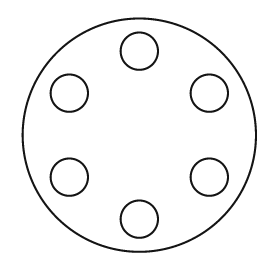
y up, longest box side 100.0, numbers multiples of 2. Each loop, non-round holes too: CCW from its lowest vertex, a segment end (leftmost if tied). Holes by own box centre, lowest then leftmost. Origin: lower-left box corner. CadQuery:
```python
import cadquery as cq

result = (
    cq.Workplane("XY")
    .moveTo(50.0, 50.0)
    .circle(50.0)
    .moveTo(50.0, 14.0)
    .circle(8.0)
    .moveTo(20.0, 32.0)
    .circle(8.0)
    .moveTo(80.0, 32.0)
    .circle(8.0)
    .moveTo(20.0, 68.0)
    .circle(8.0)
    .moveTo(80.0, 68.0)
    .circle(8.0)
    .moveTo(50.0, 86.0)
    .circle(8.0)
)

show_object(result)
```